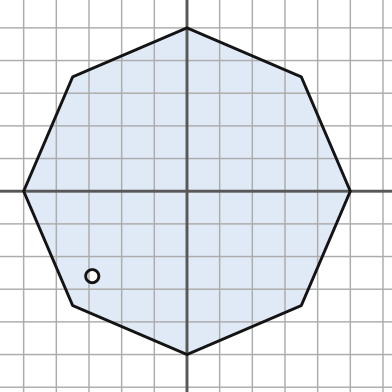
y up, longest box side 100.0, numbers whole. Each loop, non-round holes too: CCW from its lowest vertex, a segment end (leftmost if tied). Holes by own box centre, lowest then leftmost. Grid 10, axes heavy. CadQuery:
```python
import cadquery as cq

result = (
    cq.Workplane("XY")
    .moveTo(0.0, -50.0)
    .lineTo(35.0, -35.0)
    .lineTo(50.0, 0.0)
    .lineTo(35.0, 35.0)
    .lineTo(0.0, 50.0)
    .lineTo(-35.0, 35.0)
    .lineTo(-50.0, 0.0)
    .lineTo(-35.0, -35.0)
    .close()
    .moveTo(-29.0, -26.0)
    .circle(2.0)
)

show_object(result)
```